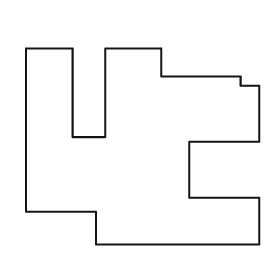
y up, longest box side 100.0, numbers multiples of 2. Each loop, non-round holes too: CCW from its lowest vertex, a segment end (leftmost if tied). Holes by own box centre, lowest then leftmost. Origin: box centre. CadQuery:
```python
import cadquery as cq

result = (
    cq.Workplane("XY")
    .moveTo(-20.0, -42.0)
    .lineTo(50.0, -42.0)
    .lineTo(50.0, -22.0)
    .lineTo(20.0, -22.0)
    .lineTo(20.0, 2.0)
    .lineTo(50.0, 2.0)
    .lineTo(50.0, 26.0)
    .lineTo(42.0, 26.0)
    .lineTo(42.0, 30.0)
    .lineTo(8.0, 30.0)
    .lineTo(8.0, 42.0)
    .lineTo(-16.0, 42.0)
    .lineTo(-16.0, 4.0)
    .lineTo(-30.0, 4.0)
    .lineTo(-30.0, 42.0)
    .lineTo(-50.0, 42.0)
    .lineTo(-50.0, -28.0)
    .lineTo(-20.0, -28.0)
    .close()
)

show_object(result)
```